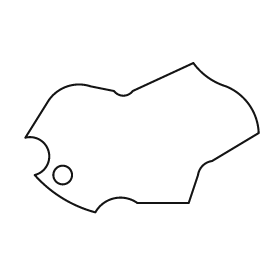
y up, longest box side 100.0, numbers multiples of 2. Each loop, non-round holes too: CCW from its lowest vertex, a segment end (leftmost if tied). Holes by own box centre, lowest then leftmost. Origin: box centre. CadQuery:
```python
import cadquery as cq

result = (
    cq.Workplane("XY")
    .moveTo(-20.0, -32.0)
    .threePointArc((-12.0, -26.0), (-2.0, -28.0))
    .lineTo(20.0, -28.0)
    .lineTo(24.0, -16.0)
    .threePointArc((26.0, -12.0), (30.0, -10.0))
    .lineTo(50.0, 2.0)
    .threePointArc((46.0, 14.0), (36.0, 22.0))
    .threePointArc((28.0, 26.0), (22.0, 32.0))
    .lineTo(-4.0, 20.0)
    .threePointArc((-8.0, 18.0), (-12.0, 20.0))
    .lineTo(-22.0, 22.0)
    .threePointArc((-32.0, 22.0), (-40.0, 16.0))
    .lineTo(-50.0, 0.0)
    .threePointArc((-40.0, -6.0), (-46.0, -16.0))
    .threePointArc((-34.0, -26.0), (-20.0, -32.0))
    .close()
    .moveTo(-34.0, -16.0)
    .circle(4.0)
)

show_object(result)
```